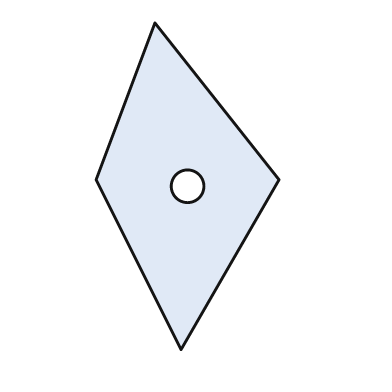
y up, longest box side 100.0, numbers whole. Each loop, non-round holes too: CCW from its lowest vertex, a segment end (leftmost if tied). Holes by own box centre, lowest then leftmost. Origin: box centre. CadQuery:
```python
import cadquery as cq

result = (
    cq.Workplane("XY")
    .moveTo(-2.0, -50.0)
    .lineTo(28.0, 2.0)
    .lineTo(-10.0, 50.0)
    .lineTo(-28.0, 2.0)
    .close()
    .moveTo(0.0, 0.0)
    .circle(5.0)
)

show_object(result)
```